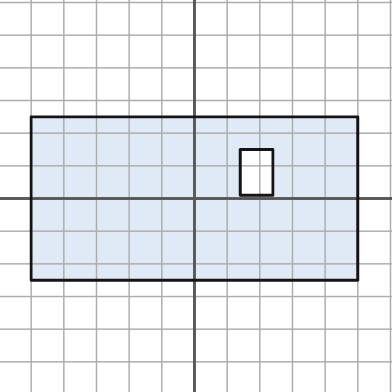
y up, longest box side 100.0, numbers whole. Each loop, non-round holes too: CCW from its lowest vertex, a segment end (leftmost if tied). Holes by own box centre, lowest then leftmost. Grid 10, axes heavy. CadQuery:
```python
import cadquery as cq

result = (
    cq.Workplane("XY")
    .moveTo(-50.0, -25.0)
    .lineTo(50.0, -25.0)
    .lineTo(50.0, 25.0)
    .lineTo(-50.0, 25.0)
    .close()
    .moveTo(14.0, 1.0)
    .lineTo(24.0, 1.0)
    .lineTo(24.0, 15.0)
    .lineTo(14.0, 15.0)
    .close()
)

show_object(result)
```